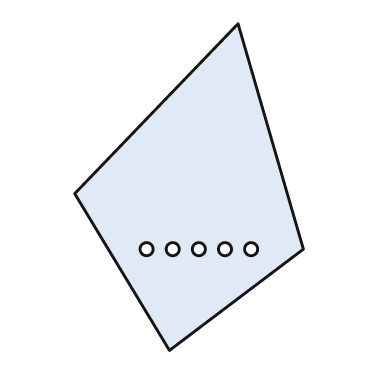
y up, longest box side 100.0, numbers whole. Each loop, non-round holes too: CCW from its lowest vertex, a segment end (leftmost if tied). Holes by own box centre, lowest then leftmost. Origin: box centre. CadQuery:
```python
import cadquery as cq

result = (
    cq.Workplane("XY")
    .moveTo(-6.0, -50.0)
    .lineTo(35.0, -19.0)
    .lineTo(15.0, 50.0)
    .lineTo(-35.0, -2.0)
    .close()
    .moveTo(-13.0, -19.0)
    .circle(2.0)
    .moveTo(-5.0, -19.0)
    .circle(2.0)
    .moveTo(3.0, -19.0)
    .circle(2.0)
    .moveTo(11.0, -19.0)
    .circle(2.0)
    .moveTo(19.0, -19.0)
    .circle(2.0)
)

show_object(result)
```